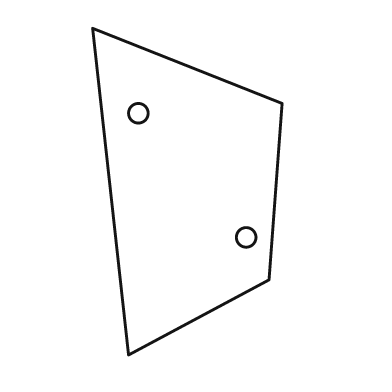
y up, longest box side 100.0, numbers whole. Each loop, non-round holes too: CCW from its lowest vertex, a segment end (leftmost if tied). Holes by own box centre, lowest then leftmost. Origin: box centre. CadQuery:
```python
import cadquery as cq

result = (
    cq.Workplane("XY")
    .moveTo(-18.0, -50.0)
    .lineTo(25.0, -27.0)
    .lineTo(29.0, 27.0)
    .lineTo(-29.0, 50.0)
    .close()
    .moveTo(18.0, -14.0)
    .circle(3.0)
    .moveTo(-15.0, 24.0)
    .circle(3.0)
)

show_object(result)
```